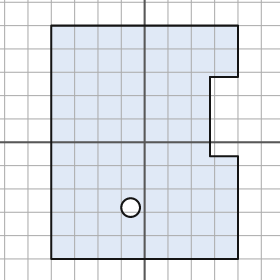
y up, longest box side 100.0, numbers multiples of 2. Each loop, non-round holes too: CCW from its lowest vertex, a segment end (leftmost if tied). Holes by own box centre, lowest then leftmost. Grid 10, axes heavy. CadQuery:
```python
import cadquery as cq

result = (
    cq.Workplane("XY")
    .moveTo(-40.0, -50.0)
    .lineTo(40.0, -50.0)
    .lineTo(40.0, -6.0)
    .lineTo(28.0, -6.0)
    .lineTo(28.0, 28.0)
    .lineTo(40.0, 28.0)
    .lineTo(40.0, 50.0)
    .lineTo(-40.0, 50.0)
    .close()
    .moveTo(-6.0, -28.0)
    .circle(4.0)
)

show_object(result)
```